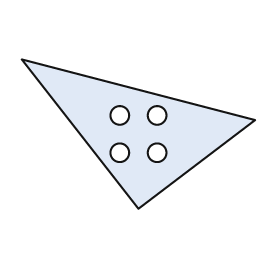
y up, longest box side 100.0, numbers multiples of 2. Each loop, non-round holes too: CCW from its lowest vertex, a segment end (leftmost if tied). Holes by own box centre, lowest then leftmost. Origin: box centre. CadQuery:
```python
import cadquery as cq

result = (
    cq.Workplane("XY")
    .moveTo(0.0, -32.0)
    .lineTo(50.0, 6.0)
    .lineTo(-50.0, 32.0)
    .close()
    .moveTo(-8.0, -8.0)
    .circle(4.0)
    .moveTo(8.0, -8.0)
    .circle(4.0)
    .moveTo(-8.0, 8.0)
    .circle(4.0)
    .moveTo(8.0, 8.0)
    .circle(4.0)
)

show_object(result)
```